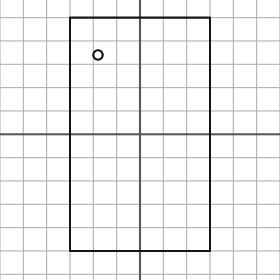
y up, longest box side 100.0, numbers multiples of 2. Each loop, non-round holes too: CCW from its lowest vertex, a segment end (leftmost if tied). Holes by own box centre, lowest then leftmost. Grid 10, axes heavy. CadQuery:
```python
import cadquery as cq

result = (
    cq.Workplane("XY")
    .moveTo(-30.0, -50.0)
    .lineTo(30.0, -50.0)
    .lineTo(30.0, 50.0)
    .lineTo(-30.0, 50.0)
    .close()
    .moveTo(-18.0, 34.0)
    .circle(2.0)
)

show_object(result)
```